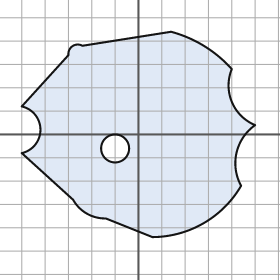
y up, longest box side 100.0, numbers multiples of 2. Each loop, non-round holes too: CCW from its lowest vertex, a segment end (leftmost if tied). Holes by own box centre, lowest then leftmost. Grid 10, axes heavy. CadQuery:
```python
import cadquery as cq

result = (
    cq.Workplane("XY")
    .moveTo(6.0, -44.0)
    .threePointArc((28.0, -38.0), (44.0, -22.0))
    .threePointArc((42.0, -8.0), (50.0, 4.0))
    .threePointArc((40.0, 14.0), (40.0, 28.0))
    .threePointArc((28.0, 38.0), (14.0, 44.0))
    .lineTo(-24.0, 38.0)
    .threePointArc((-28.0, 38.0), (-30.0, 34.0))
    .lineTo(-50.0, 12.0)
    .threePointArc((-42.0, 2.0), (-50.0, -8.0))
    .lineTo(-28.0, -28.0)
    .threePointArc((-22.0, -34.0), (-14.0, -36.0))
    .close()
    .moveTo(-10.0, -6.0)
    .circle(6.0)
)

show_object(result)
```